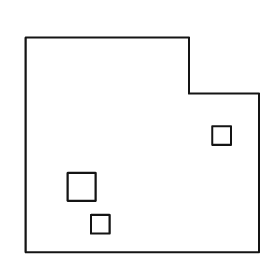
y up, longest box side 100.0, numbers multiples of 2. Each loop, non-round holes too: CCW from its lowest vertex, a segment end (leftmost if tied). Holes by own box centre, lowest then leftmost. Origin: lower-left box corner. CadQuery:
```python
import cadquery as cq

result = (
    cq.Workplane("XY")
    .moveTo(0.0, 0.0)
    .lineTo(100.0, 0.0)
    .lineTo(100.0, 68.0)
    .lineTo(70.0, 68.0)
    .lineTo(70.0, 92.0)
    .lineTo(0.0, 92.0)
    .close()
    .moveTo(28.0, 8.0)
    .lineTo(36.0, 8.0)
    .lineTo(36.0, 16.0)
    .lineTo(28.0, 16.0)
    .close()
    .moveTo(18.0, 22.0)
    .lineTo(30.0, 22.0)
    .lineTo(30.0, 34.0)
    .lineTo(18.0, 34.0)
    .close()
    .moveTo(80.0, 46.0)
    .lineTo(88.0, 46.0)
    .lineTo(88.0, 54.0)
    .lineTo(80.0, 54.0)
    .close()
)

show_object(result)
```